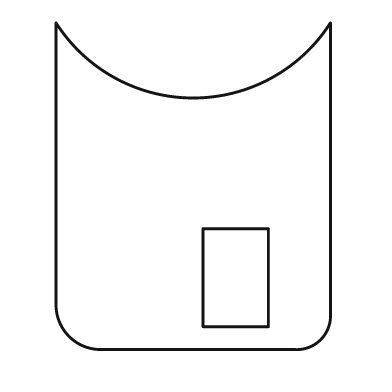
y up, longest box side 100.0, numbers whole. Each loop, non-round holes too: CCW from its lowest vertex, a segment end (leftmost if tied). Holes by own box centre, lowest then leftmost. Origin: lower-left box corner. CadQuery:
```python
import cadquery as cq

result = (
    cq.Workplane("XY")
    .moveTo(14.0, 0.0)
    .lineTo(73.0, 0.0)
    .threePointArc((81.0, 3.0), (84.0, 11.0))
    .lineTo(84.0, 100.0)
    .threePointArc((42.0, 77.0), (0.0, 100.0))
    .lineTo(0.0, 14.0)
    .threePointArc((4.0, 4.0), (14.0, 0.0))
    .close()
    .moveTo(45.0, 7.0)
    .lineTo(65.0, 7.0)
    .lineTo(65.0, 37.0)
    .lineTo(45.0, 37.0)
    .close()
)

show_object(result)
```